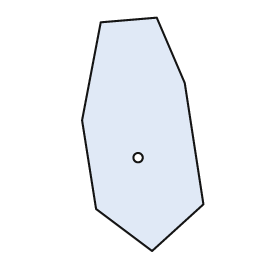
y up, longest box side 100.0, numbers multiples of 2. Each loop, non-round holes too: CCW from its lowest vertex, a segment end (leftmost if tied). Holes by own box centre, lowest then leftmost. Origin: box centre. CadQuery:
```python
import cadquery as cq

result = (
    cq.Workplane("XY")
    .moveTo(4.0, -50.0)
    .lineTo(26.0, -30.0)
    .lineTo(18.0, 22.0)
    .lineTo(6.0, 50.0)
    .lineTo(-18.0, 48.0)
    .lineTo(-26.0, 6.0)
    .lineTo(-20.0, -32.0)
    .close()
    .moveTo(-2.0, -10.0)
    .circle(2.0)
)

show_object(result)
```